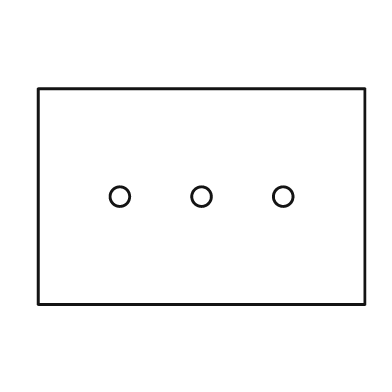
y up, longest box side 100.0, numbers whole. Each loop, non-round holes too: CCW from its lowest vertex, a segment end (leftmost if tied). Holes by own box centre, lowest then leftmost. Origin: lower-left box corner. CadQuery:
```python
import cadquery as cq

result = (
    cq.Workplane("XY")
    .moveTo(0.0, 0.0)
    .lineTo(100.0, 0.0)
    .lineTo(100.0, 66.0)
    .lineTo(0.0, 66.0)
    .close()
    .moveTo(25.0, 33.0)
    .circle(3.0)
    .moveTo(50.0, 33.0)
    .circle(3.0)
    .moveTo(75.0, 33.0)
    .circle(3.0)
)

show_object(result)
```